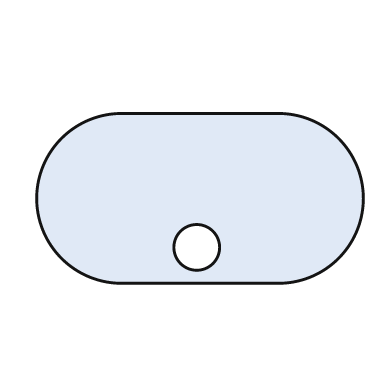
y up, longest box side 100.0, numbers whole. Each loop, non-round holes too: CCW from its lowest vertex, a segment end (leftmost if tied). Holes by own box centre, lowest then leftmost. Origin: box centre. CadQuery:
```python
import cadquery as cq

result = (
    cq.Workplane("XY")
    .moveTo(-24.0, -26.0)
    .lineTo(24.0, -26.0)
    .threePointArc((50.0, 0.0), (24.0, 26.0))
    .lineTo(-24.0, 26.0)
    .threePointArc((-50.0, 0.0), (-24.0, -26.0))
    .close()
    .moveTo(-1.0, -15.0)
    .circle(7.0)
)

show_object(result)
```